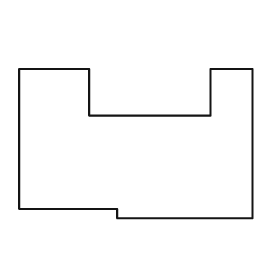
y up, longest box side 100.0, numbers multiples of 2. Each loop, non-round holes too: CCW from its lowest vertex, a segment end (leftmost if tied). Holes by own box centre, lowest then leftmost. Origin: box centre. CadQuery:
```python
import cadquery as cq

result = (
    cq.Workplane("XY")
    .moveTo(-8.0, -32.0)
    .lineTo(50.0, -32.0)
    .lineTo(50.0, 32.0)
    .lineTo(32.0, 32.0)
    .lineTo(32.0, 12.0)
    .lineTo(-20.0, 12.0)
    .lineTo(-20.0, 32.0)
    .lineTo(-50.0, 32.0)
    .lineTo(-50.0, -28.0)
    .lineTo(-8.0, -28.0)
    .close()
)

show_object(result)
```